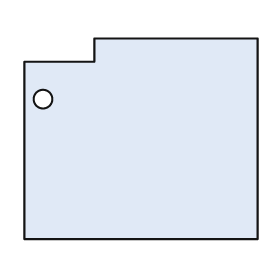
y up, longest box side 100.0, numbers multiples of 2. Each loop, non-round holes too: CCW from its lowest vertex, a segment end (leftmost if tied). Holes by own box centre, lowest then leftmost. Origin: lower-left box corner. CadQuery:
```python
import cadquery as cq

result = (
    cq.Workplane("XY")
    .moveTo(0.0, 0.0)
    .lineTo(100.0, 0.0)
    .lineTo(100.0, 86.0)
    .lineTo(30.0, 86.0)
    .lineTo(30.0, 76.0)
    .lineTo(0.0, 76.0)
    .close()
    .moveTo(8.0, 60.0)
    .circle(4.0)
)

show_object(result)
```